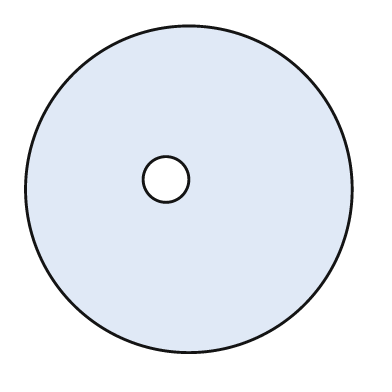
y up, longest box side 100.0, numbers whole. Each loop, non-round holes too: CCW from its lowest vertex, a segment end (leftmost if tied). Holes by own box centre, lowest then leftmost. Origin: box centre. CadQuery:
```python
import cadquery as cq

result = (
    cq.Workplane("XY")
    .moveTo(0.0, 0.0)
    .circle(50.0)
    .moveTo(-7.0, 3.0)
    .circle(7.0)
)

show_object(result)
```